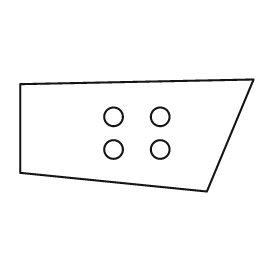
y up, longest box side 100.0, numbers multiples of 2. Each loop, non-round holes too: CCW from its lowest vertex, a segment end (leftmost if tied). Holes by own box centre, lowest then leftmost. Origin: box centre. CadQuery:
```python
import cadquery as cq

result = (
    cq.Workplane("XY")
    .moveTo(30.0, -24.0)
    .lineTo(50.0, 24.0)
    .lineTo(-50.0, 22.0)
    .lineTo(-50.0, -16.0)
    .close()
    .moveTo(-10.0, -6.0)
    .circle(4.0)
    .moveTo(10.0, -6.0)
    .circle(4.0)
    .moveTo(-10.0, 8.0)
    .circle(4.0)
    .moveTo(10.0, 8.0)
    .circle(4.0)
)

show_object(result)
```